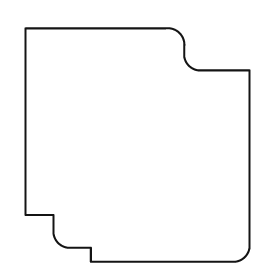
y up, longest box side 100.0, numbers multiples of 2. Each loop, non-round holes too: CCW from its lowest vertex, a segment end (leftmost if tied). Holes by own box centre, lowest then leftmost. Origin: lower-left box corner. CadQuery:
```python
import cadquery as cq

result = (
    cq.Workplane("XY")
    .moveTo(28.0, 0.0)
    .lineTo(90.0, 0.0)
    .threePointArc((94.0, 2.0), (96.0, 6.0))
    .lineTo(96.0, 82.0)
    .lineTo(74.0, 82.0)
    .threePointArc((70.0, 84.0), (68.0, 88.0))
    .lineTo(68.0, 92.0)
    .threePointArc((66.0, 98.0), (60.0, 100.0))
    .lineTo(0.0, 100.0)
    .lineTo(0.0, 20.0)
    .lineTo(12.0, 20.0)
    .lineTo(12.0, 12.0)
    .threePointArc((14.0, 8.0), (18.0, 6.0))
    .lineTo(28.0, 6.0)
    .close()
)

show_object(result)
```